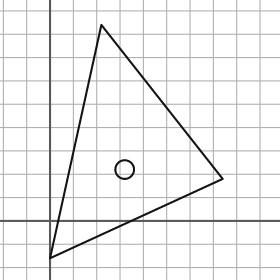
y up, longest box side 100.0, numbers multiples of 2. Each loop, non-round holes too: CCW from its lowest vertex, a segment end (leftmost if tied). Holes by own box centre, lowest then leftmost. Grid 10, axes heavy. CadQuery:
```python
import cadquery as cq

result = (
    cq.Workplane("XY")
    .moveTo(0.0, -16.0)
    .lineTo(74.0, 18.0)
    .lineTo(22.0, 84.0)
    .close()
    .moveTo(32.0, 22.0)
    .circle(4.0)
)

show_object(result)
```